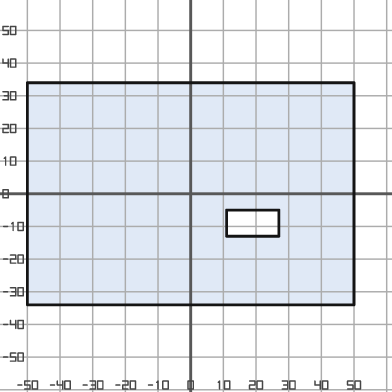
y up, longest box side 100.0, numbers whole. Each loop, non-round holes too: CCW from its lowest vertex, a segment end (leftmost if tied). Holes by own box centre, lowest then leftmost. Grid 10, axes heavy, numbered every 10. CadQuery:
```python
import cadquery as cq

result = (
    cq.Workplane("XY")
    .moveTo(-50.0, -34.0)
    .lineTo(50.0, -34.0)
    .lineTo(50.0, 34.0)
    .lineTo(-50.0, 34.0)
    .close()
    .moveTo(11.0, -13.0)
    .lineTo(27.0, -13.0)
    .lineTo(27.0, -5.0)
    .lineTo(11.0, -5.0)
    .close()
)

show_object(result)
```